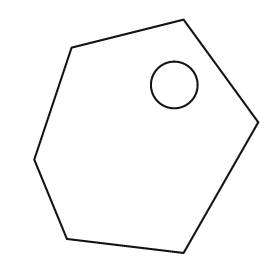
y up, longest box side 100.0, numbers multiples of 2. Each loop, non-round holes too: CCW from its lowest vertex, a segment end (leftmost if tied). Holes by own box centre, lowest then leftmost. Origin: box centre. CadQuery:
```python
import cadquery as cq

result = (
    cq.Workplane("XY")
    .moveTo(16.0, -50.0)
    .lineTo(48.0, 6.0)
    .lineTo(16.0, 50.0)
    .lineTo(-32.0, 38.0)
    .lineTo(-48.0, -10.0)
    .lineTo(-34.0, -44.0)
    .close()
    .moveTo(12.0, 22.0)
    .circle(10.0)
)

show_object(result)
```